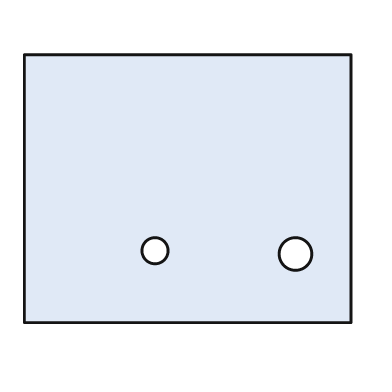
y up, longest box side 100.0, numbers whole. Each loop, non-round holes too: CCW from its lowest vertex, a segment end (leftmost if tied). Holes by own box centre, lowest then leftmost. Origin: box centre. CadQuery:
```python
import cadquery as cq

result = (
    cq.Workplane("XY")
    .moveTo(-50.0, -41.0)
    .lineTo(50.0, -41.0)
    .lineTo(50.0, 41.0)
    .lineTo(-50.0, 41.0)
    .close()
    .moveTo(33.0, -20.0)
    .circle(5.0)
    .moveTo(-10.0, -19.0)
    .circle(4.0)
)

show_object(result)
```